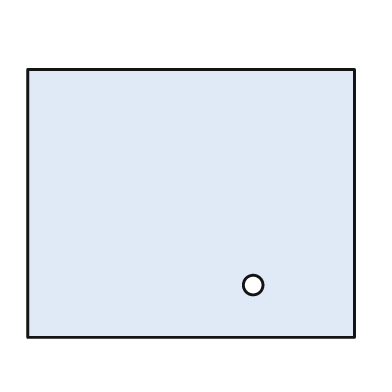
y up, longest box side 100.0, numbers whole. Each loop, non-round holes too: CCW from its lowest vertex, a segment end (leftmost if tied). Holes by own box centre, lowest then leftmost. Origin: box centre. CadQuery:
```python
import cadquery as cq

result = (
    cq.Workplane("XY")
    .moveTo(-50.0, -41.0)
    .lineTo(50.0, -41.0)
    .lineTo(50.0, 41.0)
    .lineTo(-50.0, 41.0)
    .close()
    .moveTo(19.0, -25.0)
    .circle(3.0)
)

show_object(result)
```